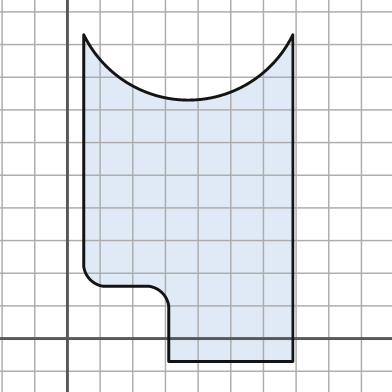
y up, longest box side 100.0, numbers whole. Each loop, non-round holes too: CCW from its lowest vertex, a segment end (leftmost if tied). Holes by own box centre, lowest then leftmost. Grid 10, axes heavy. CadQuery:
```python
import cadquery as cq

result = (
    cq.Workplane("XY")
    .moveTo(31.0, -7.0)
    .lineTo(69.0, -7.0)
    .lineTo(69.0, 93.0)
    .threePointArc((37.0, 73.0), (5.0, 93.0))
    .lineTo(5.0, 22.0)
    .threePointArc((7.0, 18.0), (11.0, 16.0))
    .lineTo(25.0, 16.0)
    .threePointArc((29.0, 14.0), (31.0, 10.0))
    .close()
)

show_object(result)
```